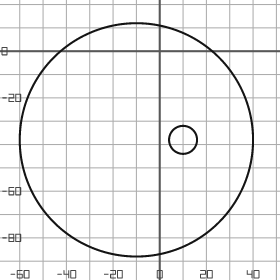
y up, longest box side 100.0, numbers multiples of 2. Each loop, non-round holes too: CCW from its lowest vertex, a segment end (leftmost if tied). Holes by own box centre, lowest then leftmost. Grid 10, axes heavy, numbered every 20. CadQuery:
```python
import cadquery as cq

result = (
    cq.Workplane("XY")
    .moveTo(-10.0, -38.0)
    .circle(50.0)
    .moveTo(10.0, -38.0)
    .circle(6.0)
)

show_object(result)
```